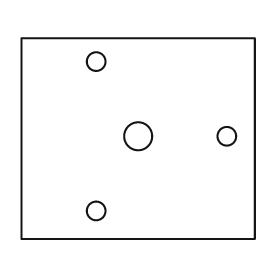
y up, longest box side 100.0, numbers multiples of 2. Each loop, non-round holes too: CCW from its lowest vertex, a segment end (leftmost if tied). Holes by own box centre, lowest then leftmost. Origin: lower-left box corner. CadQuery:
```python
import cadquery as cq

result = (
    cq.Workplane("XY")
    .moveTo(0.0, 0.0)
    .lineTo(100.0, 0.0)
    .lineTo(100.0, 86.0)
    .lineTo(0.0, 86.0)
    .close()
    .moveTo(32.0, 12.0)
    .circle(4.0)
    .moveTo(50.0, 44.0)
    .circle(6.0)
    .moveTo(88.0, 44.0)
    .circle(4.0)
    .moveTo(32.0, 76.0)
    .circle(4.0)
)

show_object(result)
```